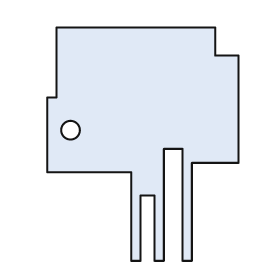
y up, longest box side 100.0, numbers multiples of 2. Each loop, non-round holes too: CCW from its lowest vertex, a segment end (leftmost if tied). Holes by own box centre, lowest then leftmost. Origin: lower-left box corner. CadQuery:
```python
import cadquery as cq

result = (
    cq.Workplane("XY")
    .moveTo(36.0, 0.0)
    .lineTo(40.0, 0.0)
    .lineTo(40.0, 28.0)
    .lineTo(46.0, 28.0)
    .lineTo(46.0, 0.0)
    .lineTo(50.0, 0.0)
    .lineTo(50.0, 48.0)
    .lineTo(58.0, 48.0)
    .lineTo(58.0, 0.0)
    .lineTo(62.0, 0.0)
    .lineTo(62.0, 42.0)
    .lineTo(82.0, 42.0)
    .lineTo(82.0, 88.0)
    .lineTo(72.0, 88.0)
    .lineTo(72.0, 100.0)
    .lineTo(4.0, 100.0)
    .lineTo(4.0, 70.0)
    .lineTo(0.0, 70.0)
    .lineTo(0.0, 38.0)
    .lineTo(36.0, 38.0)
    .close()
    .moveTo(10.0, 56.0)
    .circle(4.0)
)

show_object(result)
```